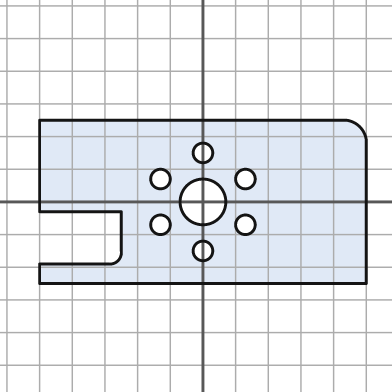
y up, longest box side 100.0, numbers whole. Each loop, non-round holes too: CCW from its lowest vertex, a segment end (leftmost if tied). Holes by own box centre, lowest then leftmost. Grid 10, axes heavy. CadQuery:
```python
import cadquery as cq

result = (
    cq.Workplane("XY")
    .moveTo(-50.0, -25.0)
    .lineTo(50.0, -25.0)
    .lineTo(50.0, 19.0)
    .threePointArc((48.0, 23.0), (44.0, 25.0))
    .lineTo(-50.0, 25.0)
    .lineTo(-50.0, -3.0)
    .lineTo(-25.0, -3.0)
    .lineTo(-25.0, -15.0)
    .threePointArc((-26.0, -18.0), (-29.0, -19.0))
    .lineTo(-50.0, -19.0)
    .close()
    .moveTo(0.0, -15.0)
    .circle(3.0)
    .moveTo(-13.0, -7.0)
    .circle(3.0)
    .moveTo(13.0, -7.0)
    .circle(3.0)
    .moveTo(0.0, 0.0)
    .circle(7.0)
    .moveTo(-13.0, 7.0)
    .circle(3.0)
    .moveTo(13.0, 7.0)
    .circle(3.0)
    .moveTo(0.0, 15.0)
    .circle(3.0)
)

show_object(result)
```